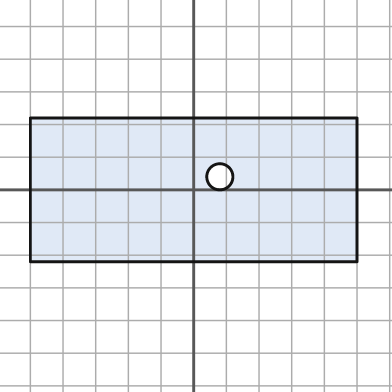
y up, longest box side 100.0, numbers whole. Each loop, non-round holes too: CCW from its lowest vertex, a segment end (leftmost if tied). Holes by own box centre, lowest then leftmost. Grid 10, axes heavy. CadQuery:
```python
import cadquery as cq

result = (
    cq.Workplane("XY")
    .moveTo(-50.0, -22.0)
    .lineTo(50.0, -22.0)
    .lineTo(50.0, 22.0)
    .lineTo(-50.0, 22.0)
    .close()
    .moveTo(8.0, 4.0)
    .circle(4.0)
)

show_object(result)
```